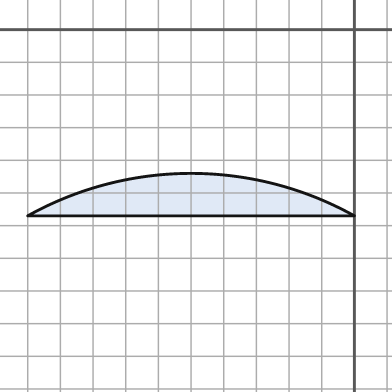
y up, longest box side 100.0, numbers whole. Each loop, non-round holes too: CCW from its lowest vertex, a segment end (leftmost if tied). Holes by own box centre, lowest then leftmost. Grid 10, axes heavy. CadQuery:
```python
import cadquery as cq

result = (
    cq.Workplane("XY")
    .moveTo(-100.0, -57.0)
    .lineTo(0.0, -57.0)
    .threePointArc((-50.0, -44.0), (-100.0, -57.0))
    .close()
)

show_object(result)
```